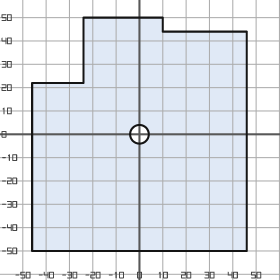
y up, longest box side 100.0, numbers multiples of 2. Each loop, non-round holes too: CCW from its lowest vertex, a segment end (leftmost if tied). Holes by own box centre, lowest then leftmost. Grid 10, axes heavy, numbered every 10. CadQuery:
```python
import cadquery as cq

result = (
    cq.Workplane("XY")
    .moveTo(-46.0, -50.0)
    .lineTo(46.0, -50.0)
    .lineTo(46.0, 44.0)
    .lineTo(10.0, 44.0)
    .lineTo(10.0, 50.0)
    .lineTo(-24.0, 50.0)
    .lineTo(-24.0, 22.0)
    .lineTo(-46.0, 22.0)
    .close()
    .moveTo(0.0, 0.0)
    .circle(4.0)
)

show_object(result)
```